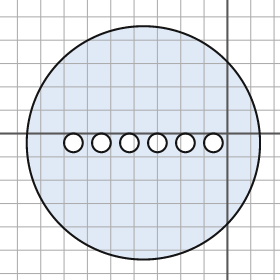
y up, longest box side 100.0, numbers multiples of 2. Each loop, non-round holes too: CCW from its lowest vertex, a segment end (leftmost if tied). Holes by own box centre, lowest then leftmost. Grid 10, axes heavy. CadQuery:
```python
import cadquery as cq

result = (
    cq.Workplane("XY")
    .moveTo(-36.0, -4.0)
    .circle(50.0)
    .moveTo(-66.0, -4.0)
    .circle(4.0)
    .moveTo(-54.0, -4.0)
    .circle(4.0)
    .moveTo(-42.0, -4.0)
    .circle(4.0)
    .moveTo(-30.0, -4.0)
    .circle(4.0)
    .moveTo(-18.0, -4.0)
    .circle(4.0)
    .moveTo(-6.0, -4.0)
    .circle(4.0)
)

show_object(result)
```